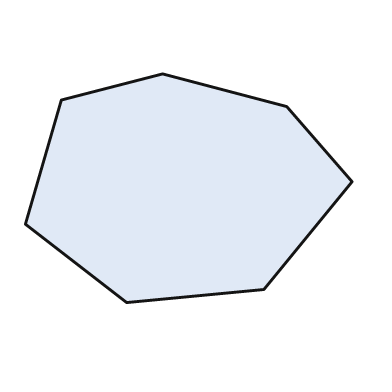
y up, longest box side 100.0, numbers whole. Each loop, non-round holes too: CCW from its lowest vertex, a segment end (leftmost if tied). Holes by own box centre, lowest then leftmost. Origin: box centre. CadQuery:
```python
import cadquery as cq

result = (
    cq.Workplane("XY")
    .moveTo(-19.0, -35.0)
    .lineTo(23.0, -31.0)
    .lineTo(50.0, 2.0)
    .lineTo(30.0, 25.0)
    .lineTo(-8.0, 35.0)
    .lineTo(-39.0, 27.0)
    .lineTo(-50.0, -11.0)
    .close()
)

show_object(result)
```